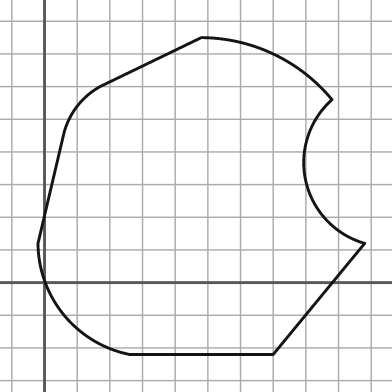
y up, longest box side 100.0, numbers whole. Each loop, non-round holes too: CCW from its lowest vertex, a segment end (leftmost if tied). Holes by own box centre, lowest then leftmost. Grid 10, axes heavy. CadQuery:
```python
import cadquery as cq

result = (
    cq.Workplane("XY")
    .moveTo(26.0, -22.0)
    .lineTo(70.0, -22.0)
    .lineTo(98.0, 12.0)
    .threePointArc((80.0, 31.0), (88.0, 56.0))
    .threePointArc((70.0, 70.0), (48.0, 75.0))
    .lineTo(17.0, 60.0)
    .threePointArc((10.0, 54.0), (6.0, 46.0))
    .lineTo(-2.0, 12.0)
    .threePointArc((6.0, -10.0), (26.0, -22.0))
    .close()
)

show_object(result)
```